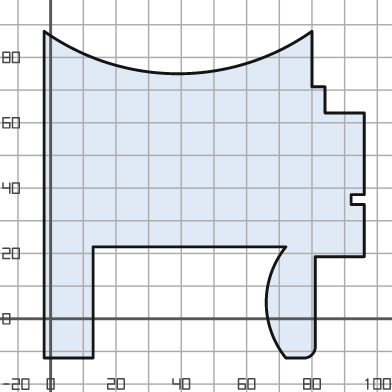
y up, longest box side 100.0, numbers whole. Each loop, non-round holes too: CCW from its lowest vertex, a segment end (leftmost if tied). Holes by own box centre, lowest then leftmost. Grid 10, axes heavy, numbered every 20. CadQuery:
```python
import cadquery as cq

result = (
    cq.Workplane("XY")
    .moveTo(-2.0, -12.0)
    .lineTo(13.0, -12.0)
    .lineTo(13.0, 22.0)
    .lineTo(72.0, 22.0)
    .threePointArc((66.0, 5.0), (72.0, -12.0))
    .lineTo(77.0, -12.0)
    .threePointArc((80.0, -11.0), (81.0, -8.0))
    .lineTo(81.0, 19.0)
    .lineTo(96.0, 19.0)
    .lineTo(96.0, 35.0)
    .lineTo(92.0, 35.0)
    .lineTo(92.0, 38.0)
    .lineTo(96.0, 38.0)
    .lineTo(96.0, 63.0)
    .lineTo(84.0, 63.0)
    .lineTo(84.0, 71.0)
    .lineTo(80.0, 71.0)
    .lineTo(80.0, 88.0)
    .threePointArc((39.0, 75.0), (-2.0, 88.0))
    .close()
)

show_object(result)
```